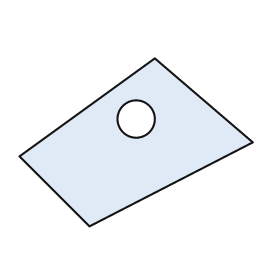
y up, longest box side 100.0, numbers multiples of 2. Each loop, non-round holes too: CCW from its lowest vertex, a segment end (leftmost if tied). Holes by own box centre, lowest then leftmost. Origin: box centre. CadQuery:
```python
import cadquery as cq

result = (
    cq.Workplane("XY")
    .moveTo(-20.0, -36.0)
    .lineTo(50.0, 0.0)
    .lineTo(8.0, 36.0)
    .lineTo(-50.0, -6.0)
    .close()
    .moveTo(0.0, 10.0)
    .circle(8.0)
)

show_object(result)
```